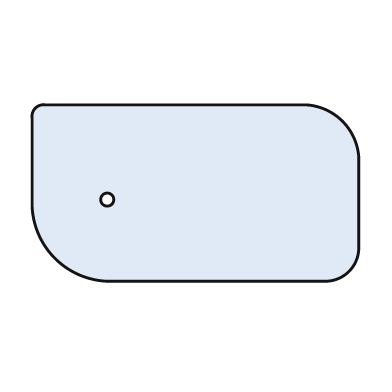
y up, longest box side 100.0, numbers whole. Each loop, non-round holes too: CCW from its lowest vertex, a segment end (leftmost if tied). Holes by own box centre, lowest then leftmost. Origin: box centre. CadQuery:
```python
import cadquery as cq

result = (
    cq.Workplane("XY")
    .moveTo(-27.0, -27.0)
    .lineTo(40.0, -27.0)
    .threePointArc((47.0, -24.0), (50.0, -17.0))
    .lineTo(50.0, 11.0)
    .threePointArc((45.0, 22.0), (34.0, 27.0))
    .lineTo(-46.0, 27.0)
    .threePointArc((-49.0, 26.0), (-50.0, 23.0))
    .lineTo(-50.0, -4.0)
    .threePointArc((-43.0, -20.0), (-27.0, -27.0))
    .close()
    .moveTo(-27.0, -2.0)
    .circle(2.0)
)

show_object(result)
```